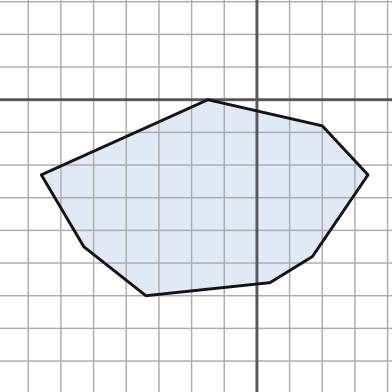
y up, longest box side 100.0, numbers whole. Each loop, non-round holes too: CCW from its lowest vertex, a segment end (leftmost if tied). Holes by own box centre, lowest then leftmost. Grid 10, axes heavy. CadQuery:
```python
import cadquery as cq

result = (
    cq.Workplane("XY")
    .moveTo(-34.0, -60.0)
    .lineTo(4.0, -56.0)
    .lineTo(17.0, -48.0)
    .lineTo(34.0, -23.0)
    .lineTo(20.0, -8.0)
    .lineTo(-15.0, 0.0)
    .lineTo(-66.0, -23.0)
    .lineTo(-53.0, -45.0)
    .close()
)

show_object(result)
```